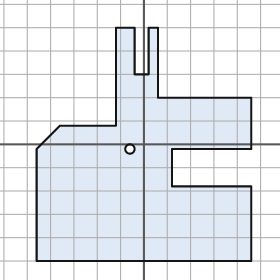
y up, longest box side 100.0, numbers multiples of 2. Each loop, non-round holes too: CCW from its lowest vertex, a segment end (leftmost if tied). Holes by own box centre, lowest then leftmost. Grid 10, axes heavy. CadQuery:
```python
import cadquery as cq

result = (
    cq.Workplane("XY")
    .moveTo(-46.0, -50.0)
    .lineTo(46.0, -50.0)
    .lineTo(46.0, -18.0)
    .lineTo(12.0, -18.0)
    .lineTo(12.0, -2.0)
    .lineTo(46.0, -2.0)
    .lineTo(46.0, 20.0)
    .lineTo(6.0, 20.0)
    .lineTo(6.0, 50.0)
    .lineTo(2.0, 50.0)
    .lineTo(2.0, 30.0)
    .lineTo(-4.0, 30.0)
    .lineTo(-4.0, 50.0)
    .lineTo(-12.0, 50.0)
    .lineTo(-12.0, 8.0)
    .lineTo(-36.0, 8.0)
    .lineTo(-46.0, -2.0)
    .close()
    .moveTo(-6.0, -2.0)
    .circle(2.0)
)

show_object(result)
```